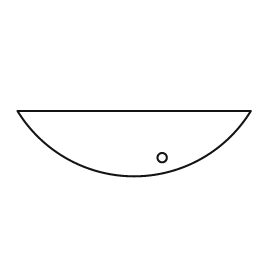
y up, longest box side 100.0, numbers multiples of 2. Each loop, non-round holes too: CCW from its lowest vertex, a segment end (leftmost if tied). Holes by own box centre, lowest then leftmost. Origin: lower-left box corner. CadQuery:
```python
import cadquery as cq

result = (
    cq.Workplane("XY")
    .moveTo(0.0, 28.0)
    .threePointArc((50.0, 0.0), (100.0, 28.0))
    .close()
    .moveTo(62.0, 8.0)
    .circle(2.0)
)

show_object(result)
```